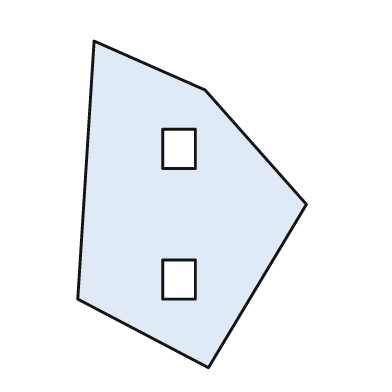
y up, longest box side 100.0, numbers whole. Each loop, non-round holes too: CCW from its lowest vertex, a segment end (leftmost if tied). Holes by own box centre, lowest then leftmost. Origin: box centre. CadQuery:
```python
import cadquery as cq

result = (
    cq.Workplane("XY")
    .moveTo(5.0, -50.0)
    .lineTo(35.0, 0.0)
    .lineTo(4.0, 35.0)
    .lineTo(-30.0, 50.0)
    .lineTo(-35.0, -29.0)
    .close()
    .moveTo(-9.0, -29.0)
    .lineTo(1.0, -29.0)
    .lineTo(1.0, -17.0)
    .lineTo(-9.0, -17.0)
    .close()
    .moveTo(-9.0, 11.0)
    .lineTo(1.0, 11.0)
    .lineTo(1.0, 23.0)
    .lineTo(-9.0, 23.0)
    .close()
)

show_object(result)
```